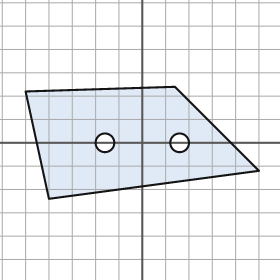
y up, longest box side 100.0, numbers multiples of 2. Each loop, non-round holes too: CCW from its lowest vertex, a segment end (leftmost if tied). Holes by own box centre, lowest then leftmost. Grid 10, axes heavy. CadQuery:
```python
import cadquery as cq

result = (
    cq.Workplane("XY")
    .moveTo(-40.0, -24.0)
    .lineTo(50.0, -12.0)
    .lineTo(14.0, 24.0)
    .lineTo(-50.0, 22.0)
    .close()
    .moveTo(-16.0, 0.0)
    .circle(4.0)
    .moveTo(16.0, 0.0)
    .circle(4.0)
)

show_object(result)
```